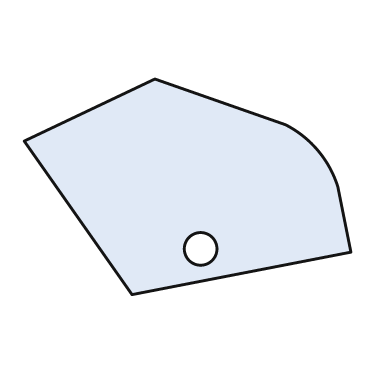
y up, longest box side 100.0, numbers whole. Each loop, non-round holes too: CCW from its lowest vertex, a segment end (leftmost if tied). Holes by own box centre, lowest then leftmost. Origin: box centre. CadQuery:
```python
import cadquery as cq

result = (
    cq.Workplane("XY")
    .moveTo(-17.0, -33.0)
    .lineTo(50.0, -20.0)
    .lineTo(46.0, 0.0)
    .threePointArc((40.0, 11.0), (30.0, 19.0))
    .lineTo(-10.0, 33.0)
    .lineTo(-50.0, 14.0)
    .close()
    .moveTo(4.0, -19.0)
    .circle(5.0)
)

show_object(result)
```